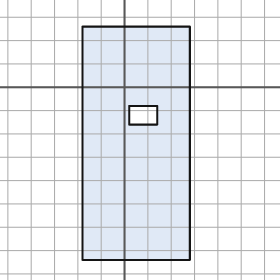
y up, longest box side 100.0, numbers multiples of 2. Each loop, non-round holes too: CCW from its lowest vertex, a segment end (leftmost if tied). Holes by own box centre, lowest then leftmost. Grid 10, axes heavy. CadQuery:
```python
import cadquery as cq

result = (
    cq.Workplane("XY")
    .moveTo(-18.0, -74.0)
    .lineTo(28.0, -74.0)
    .lineTo(28.0, 26.0)
    .lineTo(-18.0, 26.0)
    .close()
    .moveTo(2.0, -16.0)
    .lineTo(14.0, -16.0)
    .lineTo(14.0, -8.0)
    .lineTo(2.0, -8.0)
    .close()
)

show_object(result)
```